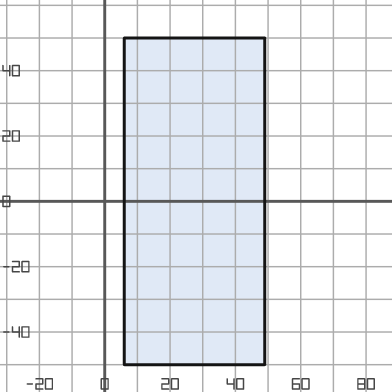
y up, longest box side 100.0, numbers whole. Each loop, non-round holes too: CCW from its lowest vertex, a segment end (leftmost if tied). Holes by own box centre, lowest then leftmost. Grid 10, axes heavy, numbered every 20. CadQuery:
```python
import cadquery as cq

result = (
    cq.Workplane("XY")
    .moveTo(6.0, -50.0)
    .lineTo(49.0, -50.0)
    .lineTo(49.0, 50.0)
    .lineTo(6.0, 50.0)
    .close()
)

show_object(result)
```